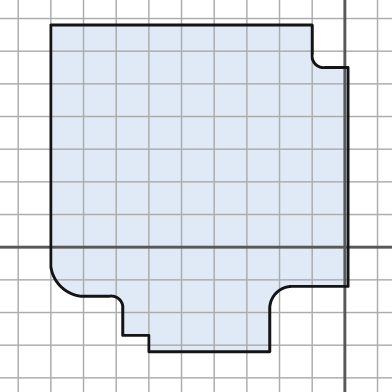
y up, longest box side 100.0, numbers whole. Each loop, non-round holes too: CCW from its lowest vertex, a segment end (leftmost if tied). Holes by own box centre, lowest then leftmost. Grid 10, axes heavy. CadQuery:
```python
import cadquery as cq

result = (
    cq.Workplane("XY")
    .moveTo(-60.0, -32.0)
    .lineTo(-23.0, -32.0)
    .lineTo(-23.0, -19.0)
    .threePointArc((-21.0, -14.0), (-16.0, -12.0))
    .lineTo(1.0, -12.0)
    .lineTo(1.0, 55.0)
    .lineTo(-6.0, 55.0)
    .threePointArc((-9.0, 56.0), (-10.0, 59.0))
    .lineTo(-10.0, 68.0)
    .lineTo(-90.0, 68.0)
    .lineTo(-90.0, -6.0)
    .threePointArc((-87.0, -12.0), (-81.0, -15.0))
    .lineTo(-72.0, -15.0)
    .threePointArc((-69.0, -16.0), (-68.0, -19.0))
    .lineTo(-68.0, -27.0)
    .lineTo(-60.0, -27.0)
    .close()
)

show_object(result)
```